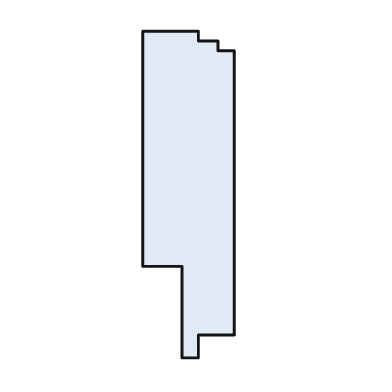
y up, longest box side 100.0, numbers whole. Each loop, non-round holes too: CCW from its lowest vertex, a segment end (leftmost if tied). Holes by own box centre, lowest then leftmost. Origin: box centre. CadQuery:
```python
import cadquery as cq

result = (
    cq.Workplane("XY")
    .moveTo(-2.0, -50.0)
    .lineTo(3.0, -50.0)
    .lineTo(3.0, -43.0)
    .lineTo(14.0, -43.0)
    .lineTo(14.0, 44.0)
    .lineTo(9.0, 44.0)
    .lineTo(9.0, 47.0)
    .lineTo(3.0, 47.0)
    .lineTo(3.0, 50.0)
    .lineTo(-14.0, 50.0)
    .lineTo(-14.0, -22.0)
    .lineTo(-2.0, -22.0)
    .close()
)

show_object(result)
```